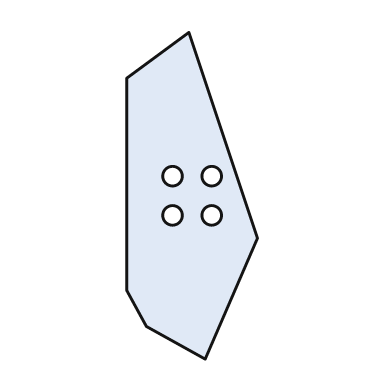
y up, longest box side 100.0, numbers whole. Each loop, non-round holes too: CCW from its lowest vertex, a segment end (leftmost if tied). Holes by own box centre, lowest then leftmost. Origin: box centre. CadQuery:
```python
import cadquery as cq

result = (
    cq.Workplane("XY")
    .moveTo(4.0, -50.0)
    .lineTo(20.0, -13.0)
    .lineTo(-1.0, 50.0)
    .lineTo(-20.0, 36.0)
    .lineTo(-20.0, -29.0)
    .lineTo(-14.0, -40.0)
    .close()
    .moveTo(-6.0, -6.0)
    .circle(3.0)
    .moveTo(6.0, -6.0)
    .circle(3.0)
    .moveTo(-6.0, 6.0)
    .circle(3.0)
    .moveTo(6.0, 6.0)
    .circle(3.0)
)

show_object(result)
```